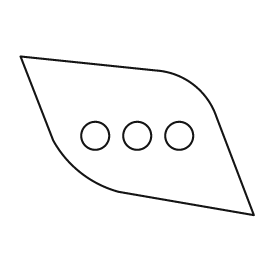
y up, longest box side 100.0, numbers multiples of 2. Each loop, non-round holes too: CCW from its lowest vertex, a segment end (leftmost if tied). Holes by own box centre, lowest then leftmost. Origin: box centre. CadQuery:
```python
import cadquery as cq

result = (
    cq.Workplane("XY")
    .moveTo(50.0, -34.0)
    .lineTo(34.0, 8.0)
    .threePointArc((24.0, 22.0), (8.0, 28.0))
    .lineTo(-50.0, 34.0)
    .lineTo(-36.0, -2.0)
    .threePointArc((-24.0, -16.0), (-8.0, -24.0))
    .close()
    .moveTo(-18.0, 0.0)
    .circle(6.0)
    .moveTo(0.0, 0.0)
    .circle(6.0)
    .moveTo(18.0, 0.0)
    .circle(6.0)
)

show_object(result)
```